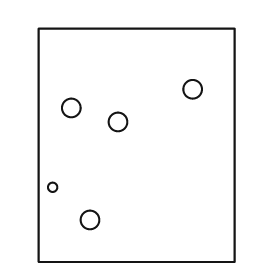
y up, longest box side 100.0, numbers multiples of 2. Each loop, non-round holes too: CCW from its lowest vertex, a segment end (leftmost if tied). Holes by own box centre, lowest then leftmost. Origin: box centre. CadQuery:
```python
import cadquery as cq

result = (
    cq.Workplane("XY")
    .moveTo(-42.0, -50.0)
    .lineTo(42.0, -50.0)
    .lineTo(42.0, 50.0)
    .lineTo(-42.0, 50.0)
    .close()
    .moveTo(-20.0, -32.0)
    .circle(4.0)
    .moveTo(-36.0, -18.0)
    .circle(2.0)
    .moveTo(-8.0, 10.0)
    .circle(4.0)
    .moveTo(-28.0, 16.0)
    .circle(4.0)
    .moveTo(24.0, 24.0)
    .circle(4.0)
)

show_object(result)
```